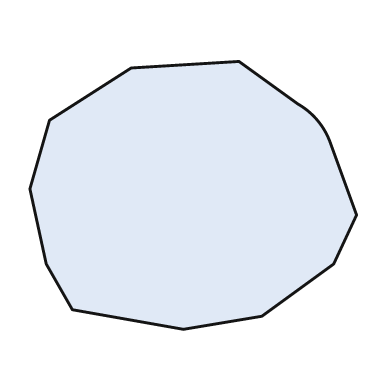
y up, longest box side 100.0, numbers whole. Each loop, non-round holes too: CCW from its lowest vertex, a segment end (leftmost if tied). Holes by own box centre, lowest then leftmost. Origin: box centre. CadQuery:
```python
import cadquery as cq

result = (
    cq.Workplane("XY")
    .moveTo(-3.0, -41.0)
    .lineTo(21.0, -37.0)
    .lineTo(43.0, -21.0)
    .lineTo(50.0, -6.0)
    .lineTo(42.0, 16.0)
    .threePointArc((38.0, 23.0), (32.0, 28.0))
    .lineTo(14.0, 41.0)
    .lineTo(-19.0, 39.0)
    .lineTo(-44.0, 23.0)
    .lineTo(-50.0, 2.0)
    .lineTo(-45.0, -21.0)
    .lineTo(-37.0, -35.0)
    .close()
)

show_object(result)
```